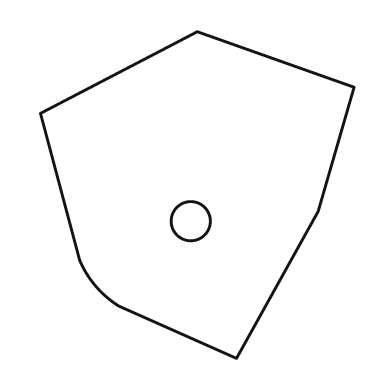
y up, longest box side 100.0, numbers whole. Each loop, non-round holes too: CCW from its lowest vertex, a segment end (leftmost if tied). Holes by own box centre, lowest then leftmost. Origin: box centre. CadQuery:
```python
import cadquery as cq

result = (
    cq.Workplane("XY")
    .moveTo(12.0, -50.0)
    .lineTo(37.0, -5.0)
    .lineTo(48.0, 33.0)
    .lineTo(0.0, 50.0)
    .lineTo(-48.0, 25.0)
    .lineTo(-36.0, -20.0)
    .threePointArc((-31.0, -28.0), (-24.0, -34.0))
    .close()
    .moveTo(-2.0, -8.0)
    .circle(6.0)
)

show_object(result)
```